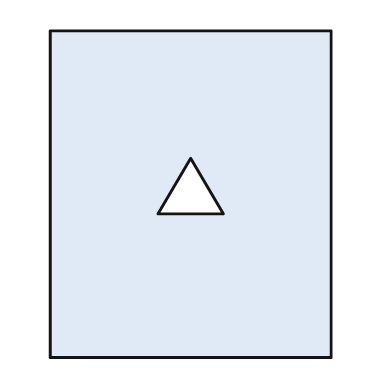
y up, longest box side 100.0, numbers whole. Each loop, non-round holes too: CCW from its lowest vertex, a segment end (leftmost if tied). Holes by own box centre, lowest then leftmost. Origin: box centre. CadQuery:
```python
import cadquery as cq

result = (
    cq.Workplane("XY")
    .moveTo(-43.0, -50.0)
    .lineTo(43.0, -50.0)
    .lineTo(43.0, 50.0)
    .lineTo(-43.0, 50.0)
    .close()
    .moveTo(-10.0, -6.0)
    .lineTo(10.0, -6.0)
    .lineTo(0.0, 11.0)
    .close()
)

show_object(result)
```